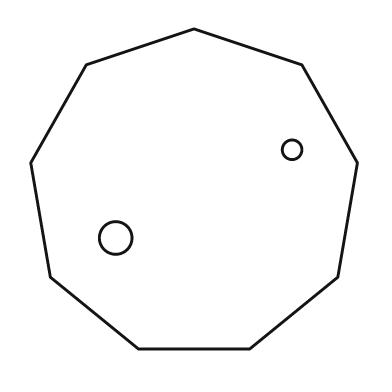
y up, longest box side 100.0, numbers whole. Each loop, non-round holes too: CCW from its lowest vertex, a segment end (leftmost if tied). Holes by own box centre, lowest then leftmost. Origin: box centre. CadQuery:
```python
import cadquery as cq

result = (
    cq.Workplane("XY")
    .moveTo(-17.0, -49.0)
    .lineTo(17.0, -49.0)
    .lineTo(44.0, -27.0)
    .lineTo(50.0, 8.0)
    .lineTo(33.0, 38.0)
    .lineTo(0.0, 49.0)
    .lineTo(-33.0, 38.0)
    .lineTo(-50.0, 8.0)
    .lineTo(-44.0, -27.0)
    .close()
    .moveTo(-24.0, -15.0)
    .circle(5.0)
    .moveTo(30.0, 12.0)
    .circle(3.0)
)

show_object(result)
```